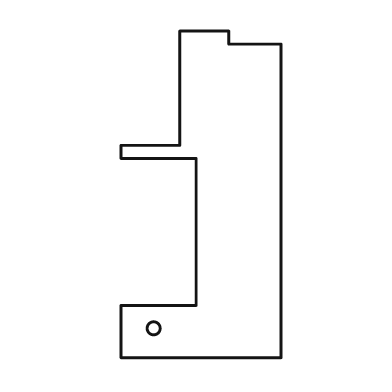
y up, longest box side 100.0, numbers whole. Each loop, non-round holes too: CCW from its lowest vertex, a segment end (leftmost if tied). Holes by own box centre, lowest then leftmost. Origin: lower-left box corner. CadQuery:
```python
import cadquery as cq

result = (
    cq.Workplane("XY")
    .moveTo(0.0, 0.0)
    .lineTo(49.0, 0.0)
    .lineTo(49.0, 96.0)
    .lineTo(33.0, 96.0)
    .lineTo(33.0, 100.0)
    .lineTo(18.0, 100.0)
    .lineTo(18.0, 65.0)
    .lineTo(0.0, 65.0)
    .lineTo(0.0, 61.0)
    .lineTo(23.0, 61.0)
    .lineTo(23.0, 16.0)
    .lineTo(0.0, 16.0)
    .close()
    .moveTo(10.0, 9.0)
    .circle(2.0)
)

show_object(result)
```